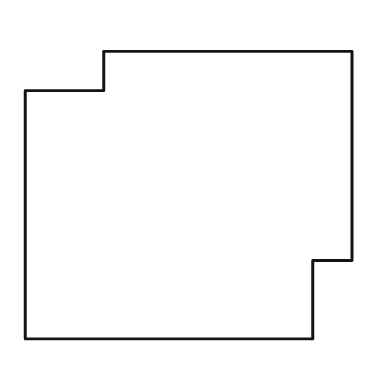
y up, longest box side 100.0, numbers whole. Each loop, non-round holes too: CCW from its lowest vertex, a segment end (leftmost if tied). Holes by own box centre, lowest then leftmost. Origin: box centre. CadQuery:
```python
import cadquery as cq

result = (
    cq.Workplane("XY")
    .moveTo(-50.0, -44.0)
    .lineTo(38.0, -44.0)
    .lineTo(38.0, -20.0)
    .lineTo(50.0, -20.0)
    .lineTo(50.0, 44.0)
    .lineTo(-26.0, 44.0)
    .lineTo(-26.0, 32.0)
    .lineTo(-50.0, 32.0)
    .close()
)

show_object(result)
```